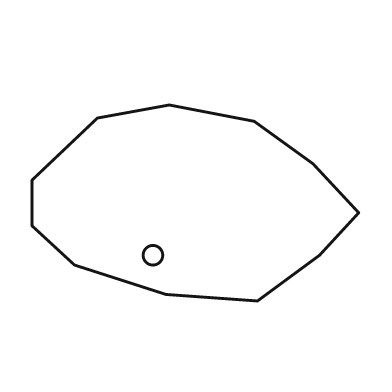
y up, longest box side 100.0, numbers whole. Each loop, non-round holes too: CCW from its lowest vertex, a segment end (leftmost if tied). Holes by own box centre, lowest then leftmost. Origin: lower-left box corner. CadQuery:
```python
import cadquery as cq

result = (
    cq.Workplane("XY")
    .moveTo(69.0, 0.0)
    .lineTo(88.0, 14.0)
    .lineTo(100.0, 27.0)
    .lineTo(86.0, 42.0)
    .lineTo(68.0, 55.0)
    .lineTo(42.0, 60.0)
    .lineTo(20.0, 56.0)
    .lineTo(0.0, 37.0)
    .lineTo(0.0, 23.0)
    .lineTo(13.0, 11.0)
    .lineTo(41.0, 2.0)
    .close()
    .moveTo(37.0, 14.0)
    .circle(3.0)
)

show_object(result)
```